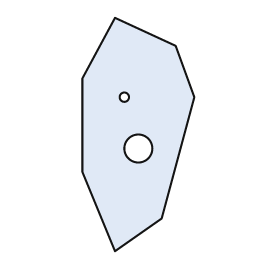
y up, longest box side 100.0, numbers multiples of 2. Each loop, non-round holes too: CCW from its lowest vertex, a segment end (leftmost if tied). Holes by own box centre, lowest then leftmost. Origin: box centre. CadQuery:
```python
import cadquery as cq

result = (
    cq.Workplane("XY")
    .moveTo(-10.0, -50.0)
    .lineTo(10.0, -36.0)
    .lineTo(24.0, 16.0)
    .lineTo(16.0, 38.0)
    .lineTo(-10.0, 50.0)
    .lineTo(-24.0, 24.0)
    .lineTo(-24.0, -16.0)
    .close()
    .moveTo(0.0, -6.0)
    .circle(6.0)
    .moveTo(-6.0, 16.0)
    .circle(2.0)
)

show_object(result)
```